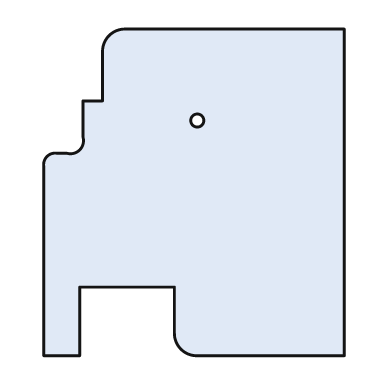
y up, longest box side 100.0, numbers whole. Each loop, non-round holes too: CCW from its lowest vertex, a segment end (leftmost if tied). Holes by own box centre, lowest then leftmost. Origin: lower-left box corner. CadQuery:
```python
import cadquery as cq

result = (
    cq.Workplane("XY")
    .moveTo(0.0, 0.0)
    .lineTo(11.0, 0.0)
    .lineTo(11.0, 21.0)
    .lineTo(40.0, 21.0)
    .lineTo(40.0, 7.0)
    .threePointArc((42.0, 2.0), (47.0, 0.0))
    .lineTo(92.0, 0.0)
    .lineTo(92.0, 100.0)
    .lineTo(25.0, 100.0)
    .threePointArc((20.0, 98.0), (18.0, 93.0))
    .lineTo(18.0, 78.0)
    .lineTo(12.0, 78.0)
    .lineTo(12.0, 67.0)
    .threePointArc((11.0, 63.0), (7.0, 62.0))
    .lineTo(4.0, 62.0)
    .threePointArc((1.0, 61.0), (0.0, 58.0))
    .close()
    .moveTo(47.0, 72.0)
    .circle(2.0)
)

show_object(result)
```